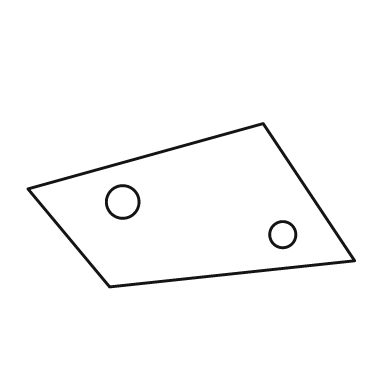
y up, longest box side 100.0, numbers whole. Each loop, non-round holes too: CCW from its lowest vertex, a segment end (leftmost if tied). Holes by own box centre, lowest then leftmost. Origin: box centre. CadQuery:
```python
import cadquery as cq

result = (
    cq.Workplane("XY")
    .moveTo(-25.0, -25.0)
    .lineTo(50.0, -17.0)
    .lineTo(22.0, 25.0)
    .lineTo(-50.0, 5.0)
    .close()
    .moveTo(28.0, -9.0)
    .circle(4.0)
    .moveTo(-21.0, 1.0)
    .circle(5.0)
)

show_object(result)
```